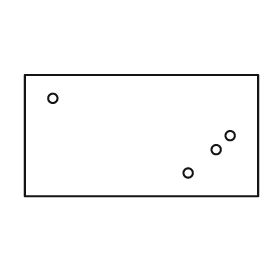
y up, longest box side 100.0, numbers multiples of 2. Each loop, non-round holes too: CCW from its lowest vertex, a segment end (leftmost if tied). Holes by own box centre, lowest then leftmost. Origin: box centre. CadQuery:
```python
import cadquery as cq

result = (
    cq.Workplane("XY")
    .moveTo(-50.0, -26.0)
    .lineTo(50.0, -26.0)
    .lineTo(50.0, 26.0)
    .lineTo(-50.0, 26.0)
    .close()
    .moveTo(20.0, -16.0)
    .circle(2.0)
    .moveTo(32.0, -6.0)
    .circle(2.0)
    .moveTo(38.0, 0.0)
    .circle(2.0)
    .moveTo(-38.0, 16.0)
    .circle(2.0)
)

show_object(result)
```